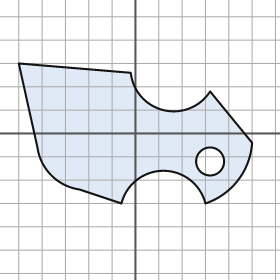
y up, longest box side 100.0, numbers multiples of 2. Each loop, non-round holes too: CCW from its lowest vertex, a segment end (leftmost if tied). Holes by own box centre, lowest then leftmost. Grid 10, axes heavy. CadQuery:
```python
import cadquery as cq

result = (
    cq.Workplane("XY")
    .moveTo(-6.0, -30.0)
    .threePointArc((12.0, -16.0), (30.0, -30.0))
    .threePointArc((44.0, -20.0), (50.0, -4.0))
    .lineTo(32.0, 18.0)
    .threePointArc((12.0, 10.0), (-2.0, 26.0))
    .lineTo(-50.0, 30.0)
    .lineTo(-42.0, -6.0)
    .threePointArc((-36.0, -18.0), (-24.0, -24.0))
    .close()
    .moveTo(32.0, -12.0)
    .circle(6.0)
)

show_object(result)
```